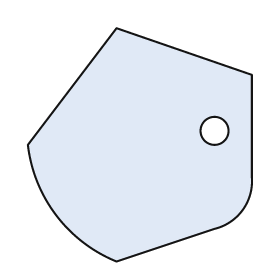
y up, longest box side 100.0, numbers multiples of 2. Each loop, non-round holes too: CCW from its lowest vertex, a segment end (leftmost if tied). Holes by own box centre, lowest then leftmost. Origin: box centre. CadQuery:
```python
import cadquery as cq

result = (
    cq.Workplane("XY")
    .moveTo(-10.0, -50.0)
    .lineTo(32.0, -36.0)
    .threePointArc((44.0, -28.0), (48.0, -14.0))
    .lineTo(48.0, 30.0)
    .lineTo(-10.0, 50.0)
    .lineTo(-48.0, 0.0)
    .threePointArc((-36.0, -30.0), (-10.0, -50.0))
    .close()
    .moveTo(32.0, 6.0)
    .circle(6.0)
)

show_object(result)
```